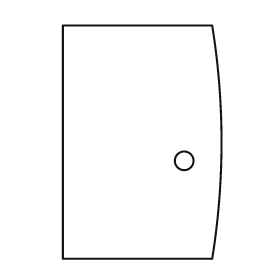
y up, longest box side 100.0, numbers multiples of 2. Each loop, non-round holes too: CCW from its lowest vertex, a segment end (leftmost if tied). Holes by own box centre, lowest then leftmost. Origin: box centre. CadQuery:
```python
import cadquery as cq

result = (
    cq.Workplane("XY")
    .moveTo(-34.0, -50.0)
    .lineTo(30.0, -50.0)
    .threePointArc((34.0, 0.0), (30.0, 50.0))
    .lineTo(-34.0, 50.0)
    .close()
    .moveTo(18.0, -8.0)
    .circle(4.0)
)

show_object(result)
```